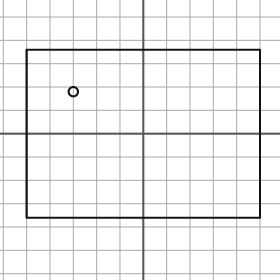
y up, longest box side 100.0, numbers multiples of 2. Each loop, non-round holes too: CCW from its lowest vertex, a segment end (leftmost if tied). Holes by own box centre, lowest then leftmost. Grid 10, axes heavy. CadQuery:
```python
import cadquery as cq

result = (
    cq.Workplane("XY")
    .moveTo(-50.0, -36.0)
    .lineTo(50.0, -36.0)
    .lineTo(50.0, 36.0)
    .lineTo(-50.0, 36.0)
    .close()
    .moveTo(-30.0, 18.0)
    .circle(2.0)
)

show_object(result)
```